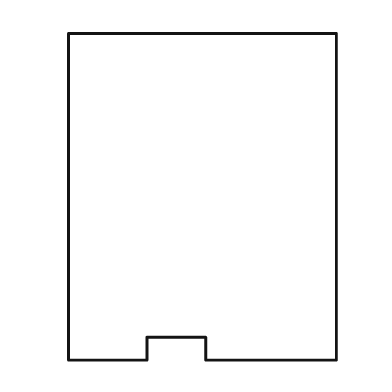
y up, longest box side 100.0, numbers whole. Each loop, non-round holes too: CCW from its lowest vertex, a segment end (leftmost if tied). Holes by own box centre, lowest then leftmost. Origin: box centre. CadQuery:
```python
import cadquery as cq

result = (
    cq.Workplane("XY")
    .moveTo(-41.0, -50.0)
    .lineTo(-17.0, -50.0)
    .lineTo(-17.0, -43.0)
    .lineTo(1.0, -43.0)
    .lineTo(1.0, -50.0)
    .lineTo(41.0, -50.0)
    .lineTo(41.0, 50.0)
    .lineTo(-41.0, 50.0)
    .close()
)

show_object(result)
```